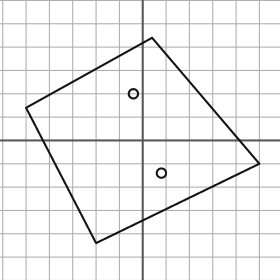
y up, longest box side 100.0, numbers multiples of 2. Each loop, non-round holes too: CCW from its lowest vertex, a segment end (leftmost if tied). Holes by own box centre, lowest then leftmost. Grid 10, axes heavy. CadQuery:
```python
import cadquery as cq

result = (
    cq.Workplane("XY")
    .moveTo(-20.0, -44.0)
    .lineTo(50.0, -10.0)
    .lineTo(4.0, 44.0)
    .lineTo(-50.0, 14.0)
    .close()
    .moveTo(8.0, -14.0)
    .circle(2.0)
    .moveTo(-4.0, 20.0)
    .circle(2.0)
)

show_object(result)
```